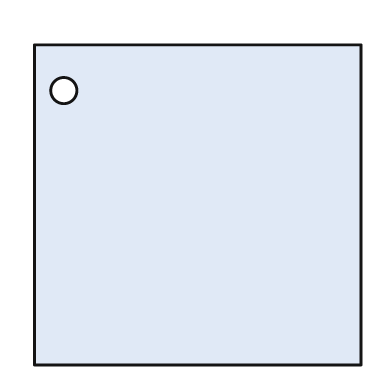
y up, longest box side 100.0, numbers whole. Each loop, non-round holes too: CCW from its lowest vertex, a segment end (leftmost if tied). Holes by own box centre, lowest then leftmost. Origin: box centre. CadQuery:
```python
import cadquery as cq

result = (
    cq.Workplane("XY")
    .moveTo(-50.0, -49.0)
    .lineTo(50.0, -49.0)
    .lineTo(50.0, 49.0)
    .lineTo(-50.0, 49.0)
    .close()
    .moveTo(-41.0, 35.0)
    .circle(4.0)
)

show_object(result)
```